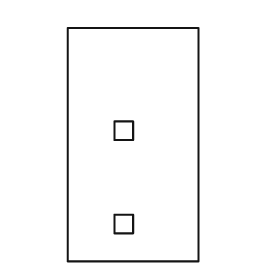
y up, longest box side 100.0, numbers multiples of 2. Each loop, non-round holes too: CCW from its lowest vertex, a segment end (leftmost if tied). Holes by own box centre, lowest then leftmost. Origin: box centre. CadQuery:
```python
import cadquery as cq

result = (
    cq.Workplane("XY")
    .moveTo(-28.0, -50.0)
    .lineTo(28.0, -50.0)
    .lineTo(28.0, 50.0)
    .lineTo(-28.0, 50.0)
    .close()
    .moveTo(-8.0, -38.0)
    .lineTo(0.0, -38.0)
    .lineTo(0.0, -30.0)
    .lineTo(-8.0, -30.0)
    .close()
    .moveTo(-8.0, 2.0)
    .lineTo(0.0, 2.0)
    .lineTo(0.0, 10.0)
    .lineTo(-8.0, 10.0)
    .close()
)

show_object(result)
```